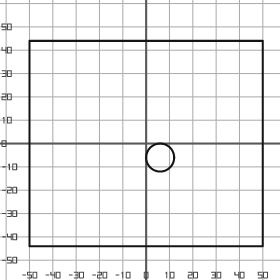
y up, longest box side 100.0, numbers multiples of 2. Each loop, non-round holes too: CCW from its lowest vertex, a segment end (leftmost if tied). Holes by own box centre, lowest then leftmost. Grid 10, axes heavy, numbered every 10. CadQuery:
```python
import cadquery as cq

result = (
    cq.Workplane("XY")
    .moveTo(-50.0, -44.0)
    .lineTo(50.0, -44.0)
    .lineTo(50.0, 44.0)
    .lineTo(-50.0, 44.0)
    .close()
    .moveTo(6.0, -6.0)
    .circle(6.0)
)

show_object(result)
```